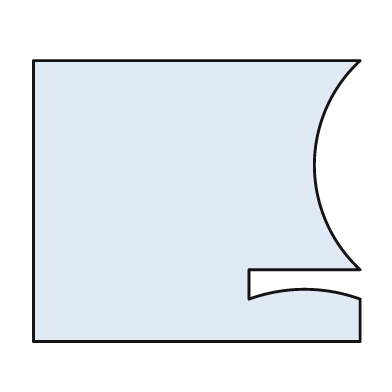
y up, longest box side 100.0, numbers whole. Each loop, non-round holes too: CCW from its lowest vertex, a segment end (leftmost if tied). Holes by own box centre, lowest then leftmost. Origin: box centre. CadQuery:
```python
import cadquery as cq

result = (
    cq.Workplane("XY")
    .moveTo(-50.0, -43.0)
    .lineTo(50.0, -43.0)
    .lineTo(50.0, -30.0)
    .threePointArc((33.0, -27.0), (16.0, -30.0))
    .lineTo(16.0, -21.0)
    .lineTo(50.0, -21.0)
    .threePointArc((36.0, 11.0), (50.0, 43.0))
    .lineTo(-50.0, 43.0)
    .close()
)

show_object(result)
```